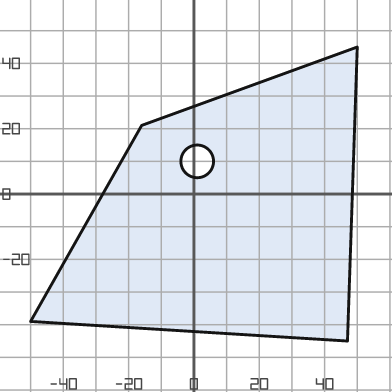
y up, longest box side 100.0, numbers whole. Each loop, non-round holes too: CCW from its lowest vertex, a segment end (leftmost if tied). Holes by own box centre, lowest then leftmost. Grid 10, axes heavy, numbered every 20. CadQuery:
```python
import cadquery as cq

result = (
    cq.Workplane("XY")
    .moveTo(47.0, -45.0)
    .lineTo(50.0, 45.0)
    .lineTo(-16.0, 21.0)
    .lineTo(-50.0, -39.0)
    .close()
    .moveTo(1.0, 10.0)
    .circle(5.0)
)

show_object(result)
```